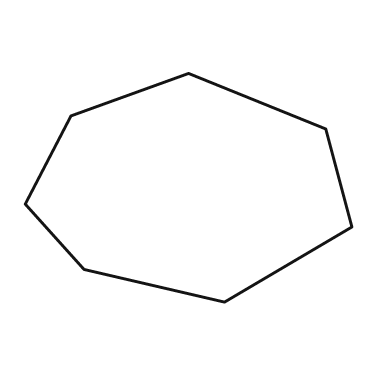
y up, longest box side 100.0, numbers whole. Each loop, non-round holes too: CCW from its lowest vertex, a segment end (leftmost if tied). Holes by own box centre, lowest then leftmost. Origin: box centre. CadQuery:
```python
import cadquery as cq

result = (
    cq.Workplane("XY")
    .moveTo(11.0, -35.0)
    .lineTo(50.0, -12.0)
    .lineTo(42.0, 18.0)
    .lineTo(0.0, 35.0)
    .lineTo(-36.0, 22.0)
    .lineTo(-50.0, -5.0)
    .lineTo(-32.0, -25.0)
    .close()
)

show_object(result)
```